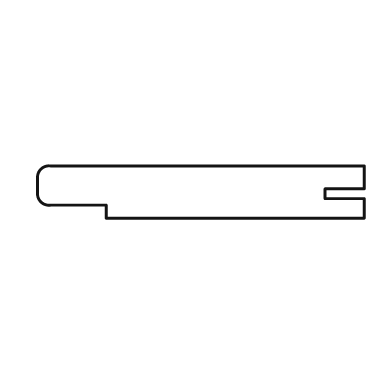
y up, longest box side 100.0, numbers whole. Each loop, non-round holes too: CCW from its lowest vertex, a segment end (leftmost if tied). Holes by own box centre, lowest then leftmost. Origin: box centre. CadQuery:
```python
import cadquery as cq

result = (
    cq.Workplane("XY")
    .moveTo(-29.0, -8.0)
    .lineTo(50.0, -8.0)
    .lineTo(50.0, -2.0)
    .lineTo(38.0, -2.0)
    .lineTo(38.0, 1.0)
    .lineTo(50.0, 1.0)
    .lineTo(50.0, 8.0)
    .lineTo(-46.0, 8.0)
    .threePointArc((-49.0, 7.0), (-50.0, 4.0))
    .lineTo(-50.0, 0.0)
    .threePointArc((-49.0, -3.0), (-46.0, -4.0))
    .lineTo(-29.0, -4.0)
    .close()
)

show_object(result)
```